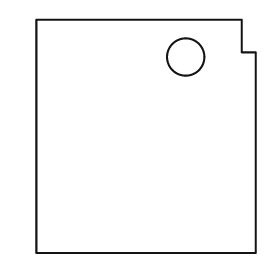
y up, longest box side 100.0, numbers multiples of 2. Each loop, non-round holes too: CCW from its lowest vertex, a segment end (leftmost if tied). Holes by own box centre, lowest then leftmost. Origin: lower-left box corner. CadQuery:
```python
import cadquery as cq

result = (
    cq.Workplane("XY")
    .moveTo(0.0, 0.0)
    .lineTo(94.0, 0.0)
    .lineTo(94.0, 86.0)
    .lineTo(88.0, 86.0)
    .lineTo(88.0, 100.0)
    .lineTo(0.0, 100.0)
    .close()
    .moveTo(64.0, 84.0)
    .circle(8.0)
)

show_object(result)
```